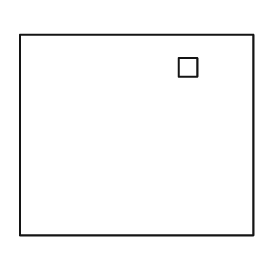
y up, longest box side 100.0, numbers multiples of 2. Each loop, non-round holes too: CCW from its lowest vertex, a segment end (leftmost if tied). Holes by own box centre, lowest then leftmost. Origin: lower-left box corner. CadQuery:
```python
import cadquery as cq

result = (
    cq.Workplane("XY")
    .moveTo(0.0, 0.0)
    .lineTo(100.0, 0.0)
    .lineTo(100.0, 86.0)
    .lineTo(0.0, 86.0)
    .close()
    .moveTo(68.0, 68.0)
    .lineTo(76.0, 68.0)
    .lineTo(76.0, 76.0)
    .lineTo(68.0, 76.0)
    .close()
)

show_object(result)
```